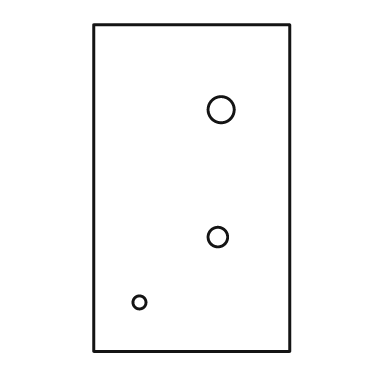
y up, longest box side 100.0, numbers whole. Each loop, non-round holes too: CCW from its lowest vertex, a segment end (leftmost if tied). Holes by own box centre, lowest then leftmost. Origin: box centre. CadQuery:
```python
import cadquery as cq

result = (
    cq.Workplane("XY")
    .moveTo(-30.0, -50.0)
    .lineTo(30.0, -50.0)
    .lineTo(30.0, 50.0)
    .lineTo(-30.0, 50.0)
    .close()
    .moveTo(-16.0, -35.0)
    .circle(2.0)
    .moveTo(8.0, -15.0)
    .circle(3.0)
    .moveTo(9.0, 24.0)
    .circle(4.0)
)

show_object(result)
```